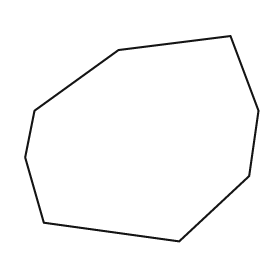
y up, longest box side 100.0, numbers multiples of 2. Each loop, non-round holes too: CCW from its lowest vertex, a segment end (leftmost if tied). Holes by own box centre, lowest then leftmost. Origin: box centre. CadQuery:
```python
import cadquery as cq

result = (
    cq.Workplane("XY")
    .moveTo(16.0, -44.0)
    .lineTo(46.0, -16.0)
    .lineTo(50.0, 12.0)
    .lineTo(38.0, 44.0)
    .lineTo(-10.0, 38.0)
    .lineTo(-46.0, 12.0)
    .lineTo(-50.0, -8.0)
    .lineTo(-42.0, -36.0)
    .close()
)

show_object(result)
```